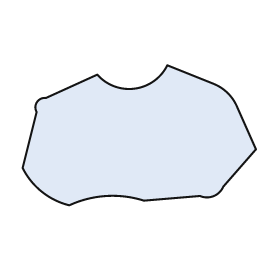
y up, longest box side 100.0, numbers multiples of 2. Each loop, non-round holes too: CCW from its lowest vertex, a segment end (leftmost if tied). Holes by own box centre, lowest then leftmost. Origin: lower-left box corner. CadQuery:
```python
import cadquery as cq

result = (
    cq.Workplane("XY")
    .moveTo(20.0, 0.0)
    .threePointArc((36.0, 4.0), (52.0, 2.0))
    .lineTo(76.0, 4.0)
    .threePointArc((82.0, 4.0), (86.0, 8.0))
    .lineTo(100.0, 24.0)
    .lineTo(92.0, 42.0)
    .threePointArc((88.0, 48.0), (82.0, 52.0))
    .lineTo(62.0, 60.0)
    .threePointArc((48.0, 50.0), (32.0, 56.0))
    .lineTo(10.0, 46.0)
    .threePointArc((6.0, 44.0), (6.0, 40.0))
    .lineTo(0.0, 16.0)
    .threePointArc((8.0, 6.0), (20.0, 0.0))
    .close()
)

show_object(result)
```